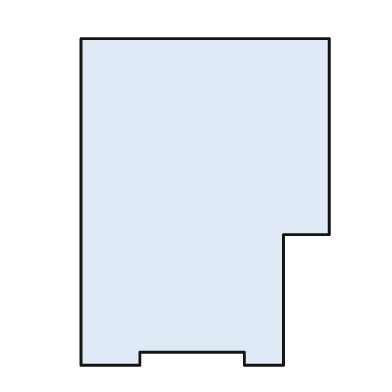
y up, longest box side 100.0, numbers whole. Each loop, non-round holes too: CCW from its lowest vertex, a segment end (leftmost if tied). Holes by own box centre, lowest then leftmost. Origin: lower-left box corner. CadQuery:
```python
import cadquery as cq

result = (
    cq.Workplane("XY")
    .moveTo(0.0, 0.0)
    .lineTo(18.0, 0.0)
    .lineTo(18.0, 4.0)
    .lineTo(50.0, 4.0)
    .lineTo(50.0, 0.0)
    .lineTo(62.0, 0.0)
    .lineTo(62.0, 40.0)
    .lineTo(76.0, 40.0)
    .lineTo(76.0, 100.0)
    .lineTo(0.0, 100.0)
    .close()
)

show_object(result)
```